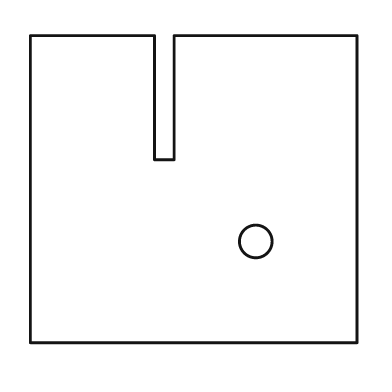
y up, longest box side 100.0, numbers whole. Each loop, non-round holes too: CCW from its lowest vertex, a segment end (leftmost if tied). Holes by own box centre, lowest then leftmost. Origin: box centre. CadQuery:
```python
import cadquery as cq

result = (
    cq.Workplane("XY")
    .moveTo(-50.0, -47.0)
    .lineTo(50.0, -47.0)
    .lineTo(50.0, 47.0)
    .lineTo(-6.0, 47.0)
    .lineTo(-6.0, 9.0)
    .lineTo(-12.0, 9.0)
    .lineTo(-12.0, 47.0)
    .lineTo(-50.0, 47.0)
    .close()
    .moveTo(19.0, -16.0)
    .circle(5.0)
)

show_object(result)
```